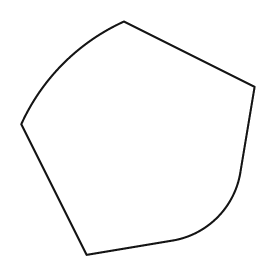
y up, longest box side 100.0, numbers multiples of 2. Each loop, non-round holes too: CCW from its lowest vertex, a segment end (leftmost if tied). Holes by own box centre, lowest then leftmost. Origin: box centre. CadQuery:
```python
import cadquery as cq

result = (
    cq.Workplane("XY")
    .moveTo(-22.0, -50.0)
    .lineTo(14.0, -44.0)
    .threePointArc((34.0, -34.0), (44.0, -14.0))
    .lineTo(50.0, 22.0)
    .lineTo(-6.0, 50.0)
    .threePointArc((-32.0, 32.0), (-50.0, 6.0))
    .close()
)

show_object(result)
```